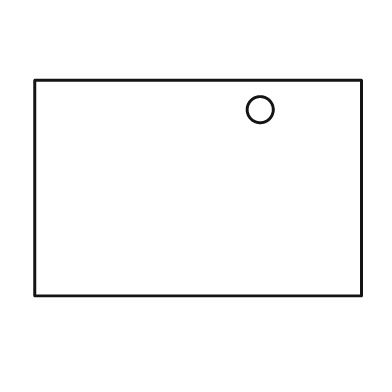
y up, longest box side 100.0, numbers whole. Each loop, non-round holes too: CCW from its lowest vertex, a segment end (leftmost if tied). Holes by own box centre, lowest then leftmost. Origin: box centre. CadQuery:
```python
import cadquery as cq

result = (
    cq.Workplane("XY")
    .moveTo(-50.0, -33.0)
    .lineTo(50.0, -33.0)
    .lineTo(50.0, 33.0)
    .lineTo(-50.0, 33.0)
    .close()
    .moveTo(19.0, 24.0)
    .circle(4.0)
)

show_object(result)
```